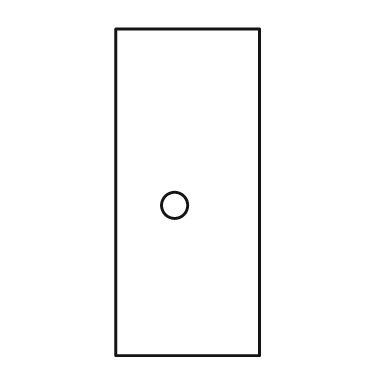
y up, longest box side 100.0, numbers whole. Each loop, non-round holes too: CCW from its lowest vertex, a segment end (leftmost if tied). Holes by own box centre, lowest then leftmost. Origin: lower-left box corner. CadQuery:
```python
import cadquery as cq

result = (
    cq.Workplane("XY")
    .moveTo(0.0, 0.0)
    .lineTo(44.0, 0.0)
    .lineTo(44.0, 100.0)
    .lineTo(0.0, 100.0)
    .close()
    .moveTo(18.0, 46.0)
    .circle(4.0)
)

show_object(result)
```